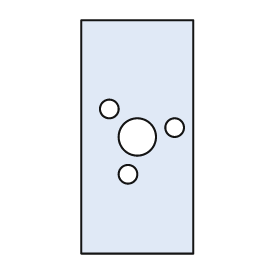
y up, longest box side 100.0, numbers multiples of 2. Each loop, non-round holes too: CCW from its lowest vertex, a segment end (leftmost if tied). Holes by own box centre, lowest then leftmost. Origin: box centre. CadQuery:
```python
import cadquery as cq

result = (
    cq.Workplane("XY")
    .moveTo(-24.0, -50.0)
    .lineTo(24.0, -50.0)
    .lineTo(24.0, 50.0)
    .lineTo(-24.0, 50.0)
    .close()
    .moveTo(-4.0, -16.0)
    .circle(4.0)
    .moveTo(0.0, 0.0)
    .circle(8.0)
    .moveTo(16.0, 4.0)
    .circle(4.0)
    .moveTo(-12.0, 12.0)
    .circle(4.0)
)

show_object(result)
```